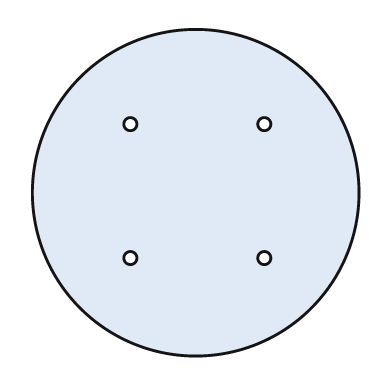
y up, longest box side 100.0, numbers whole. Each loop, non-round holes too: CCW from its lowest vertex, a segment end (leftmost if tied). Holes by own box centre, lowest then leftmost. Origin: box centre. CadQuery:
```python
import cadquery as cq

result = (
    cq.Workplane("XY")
    .moveTo(0.0, 0.0)
    .circle(50.0)
    .moveTo(-20.0, -20.0)
    .circle(2.0)
    .moveTo(21.0, -20.0)
    .circle(2.0)
    .moveTo(-20.0, 21.0)
    .circle(2.0)
    .moveTo(21.0, 21.0)
    .circle(2.0)
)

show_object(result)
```